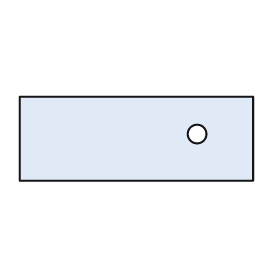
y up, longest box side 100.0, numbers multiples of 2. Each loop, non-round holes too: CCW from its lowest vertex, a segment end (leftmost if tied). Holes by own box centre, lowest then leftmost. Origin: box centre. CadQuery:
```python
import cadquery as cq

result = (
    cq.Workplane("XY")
    .moveTo(-50.0, -18.0)
    .lineTo(50.0, -18.0)
    .lineTo(50.0, 18.0)
    .lineTo(-50.0, 18.0)
    .close()
    .moveTo(26.0, 2.0)
    .circle(4.0)
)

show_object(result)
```